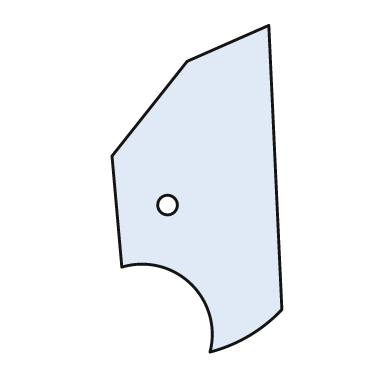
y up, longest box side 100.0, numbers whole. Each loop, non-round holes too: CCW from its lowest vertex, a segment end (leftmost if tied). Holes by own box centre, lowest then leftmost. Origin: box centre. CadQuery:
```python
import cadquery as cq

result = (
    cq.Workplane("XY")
    .moveTo(4.0, -50.0)
    .threePointArc((16.0, -45.0), (26.0, -37.0))
    .lineTo(22.0, 50.0)
    .lineTo(-3.0, 39.0)
    .lineTo(-26.0, 10.0)
    .lineTo(-23.0, -24.0)
    .threePointArc((-2.0, -29.0), (4.0, -50.0))
    .close()
    .moveTo(-9.0, -5.0)
    .circle(3.0)
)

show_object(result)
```